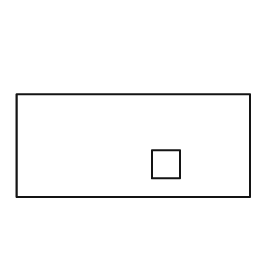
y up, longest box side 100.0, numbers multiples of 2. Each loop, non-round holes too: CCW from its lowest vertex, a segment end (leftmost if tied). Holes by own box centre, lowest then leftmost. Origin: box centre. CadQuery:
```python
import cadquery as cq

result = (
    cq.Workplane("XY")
    .moveTo(-50.0, -22.0)
    .lineTo(50.0, -22.0)
    .lineTo(50.0, 22.0)
    .lineTo(-50.0, 22.0)
    .close()
    .moveTo(8.0, -14.0)
    .lineTo(20.0, -14.0)
    .lineTo(20.0, -2.0)
    .lineTo(8.0, -2.0)
    .close()
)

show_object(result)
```